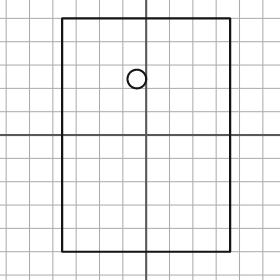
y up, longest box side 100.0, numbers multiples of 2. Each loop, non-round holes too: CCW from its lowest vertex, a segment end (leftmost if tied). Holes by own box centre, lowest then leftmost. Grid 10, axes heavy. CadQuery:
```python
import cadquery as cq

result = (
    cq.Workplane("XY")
    .moveTo(-36.0, -50.0)
    .lineTo(36.0, -50.0)
    .lineTo(36.0, 50.0)
    .lineTo(-36.0, 50.0)
    .close()
    .moveTo(-4.0, 24.0)
    .circle(4.0)
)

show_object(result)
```